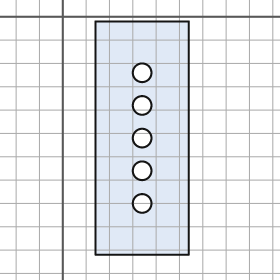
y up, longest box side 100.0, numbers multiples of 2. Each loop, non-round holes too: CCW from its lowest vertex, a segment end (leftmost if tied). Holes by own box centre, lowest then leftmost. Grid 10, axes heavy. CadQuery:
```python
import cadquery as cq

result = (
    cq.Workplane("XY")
    .moveTo(14.0, -102.0)
    .lineTo(54.0, -102.0)
    .lineTo(54.0, -2.0)
    .lineTo(14.0, -2.0)
    .close()
    .moveTo(34.0, -80.0)
    .circle(4.0)
    .moveTo(34.0, -66.0)
    .circle(4.0)
    .moveTo(34.0, -52.0)
    .circle(4.0)
    .moveTo(34.0, -38.0)
    .circle(4.0)
    .moveTo(34.0, -24.0)
    .circle(4.0)
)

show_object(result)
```